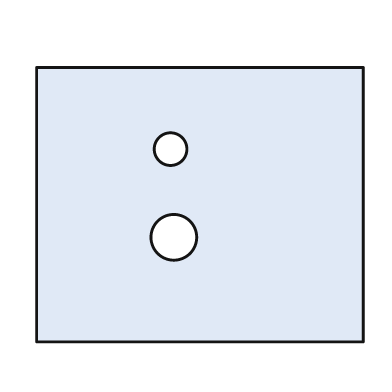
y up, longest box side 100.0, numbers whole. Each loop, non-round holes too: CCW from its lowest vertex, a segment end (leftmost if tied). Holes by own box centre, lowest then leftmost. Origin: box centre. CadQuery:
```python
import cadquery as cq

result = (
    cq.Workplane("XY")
    .moveTo(-50.0, -42.0)
    .lineTo(50.0, -42.0)
    .lineTo(50.0, 42.0)
    .lineTo(-50.0, 42.0)
    .close()
    .moveTo(-8.0, -10.0)
    .circle(7.0)
    .moveTo(-9.0, 17.0)
    .circle(5.0)
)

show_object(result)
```